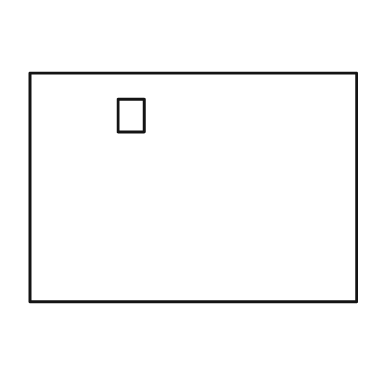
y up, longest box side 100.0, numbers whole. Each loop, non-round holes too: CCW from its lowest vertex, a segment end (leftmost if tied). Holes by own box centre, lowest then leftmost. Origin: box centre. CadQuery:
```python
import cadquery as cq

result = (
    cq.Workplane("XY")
    .moveTo(-50.0, -35.0)
    .lineTo(50.0, -35.0)
    .lineTo(50.0, 35.0)
    .lineTo(-50.0, 35.0)
    .close()
    .moveTo(-23.0, 17.0)
    .lineTo(-15.0, 17.0)
    .lineTo(-15.0, 27.0)
    .lineTo(-23.0, 27.0)
    .close()
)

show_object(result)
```